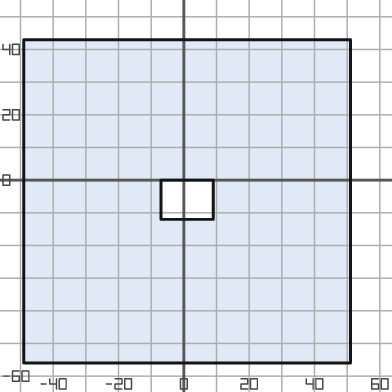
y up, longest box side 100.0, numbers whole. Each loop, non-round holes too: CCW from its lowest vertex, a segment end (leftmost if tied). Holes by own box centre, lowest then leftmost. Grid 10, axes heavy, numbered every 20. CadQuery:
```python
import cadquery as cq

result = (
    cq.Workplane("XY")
    .moveTo(-49.0, -56.0)
    .lineTo(51.0, -56.0)
    .lineTo(51.0, 43.0)
    .lineTo(-49.0, 43.0)
    .close()
    .moveTo(-7.0, -12.0)
    .lineTo(9.0, -12.0)
    .lineTo(9.0, 0.0)
    .lineTo(-7.0, 0.0)
    .close()
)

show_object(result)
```